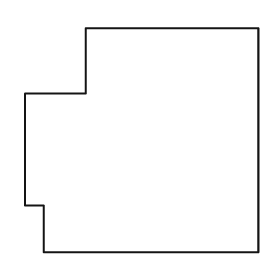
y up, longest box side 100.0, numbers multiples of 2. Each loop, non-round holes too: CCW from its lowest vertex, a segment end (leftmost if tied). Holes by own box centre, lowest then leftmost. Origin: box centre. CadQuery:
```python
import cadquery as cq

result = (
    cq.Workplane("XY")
    .moveTo(-42.0, -48.0)
    .lineTo(50.0, -48.0)
    .lineTo(50.0, 48.0)
    .lineTo(-24.0, 48.0)
    .lineTo(-24.0, 20.0)
    .lineTo(-50.0, 20.0)
    .lineTo(-50.0, -28.0)
    .lineTo(-42.0, -28.0)
    .close()
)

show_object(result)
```